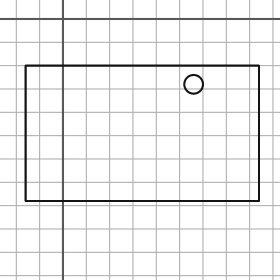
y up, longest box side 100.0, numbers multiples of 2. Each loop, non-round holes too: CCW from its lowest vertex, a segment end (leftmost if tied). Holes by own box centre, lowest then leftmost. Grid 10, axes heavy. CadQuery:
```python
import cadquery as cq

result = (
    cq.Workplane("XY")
    .moveTo(-16.0, -78.0)
    .lineTo(84.0, -78.0)
    .lineTo(84.0, -20.0)
    .lineTo(-16.0, -20.0)
    .close()
    .moveTo(56.0, -28.0)
    .circle(4.0)
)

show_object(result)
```